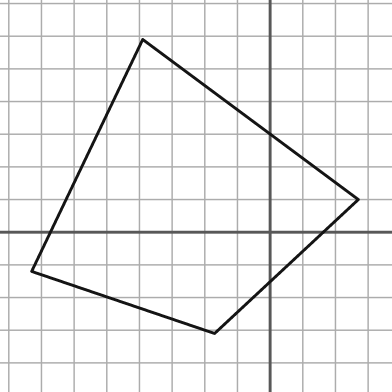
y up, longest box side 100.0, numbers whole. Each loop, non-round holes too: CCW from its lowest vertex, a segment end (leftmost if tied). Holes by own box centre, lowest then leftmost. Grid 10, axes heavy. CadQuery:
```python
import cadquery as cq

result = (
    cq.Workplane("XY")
    .moveTo(-17.0, -31.0)
    .lineTo(27.0, 10.0)
    .lineTo(-39.0, 59.0)
    .lineTo(-73.0, -12.0)
    .close()
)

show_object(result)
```